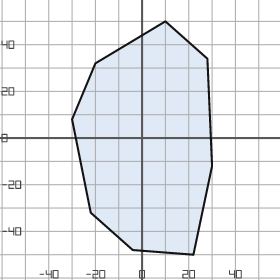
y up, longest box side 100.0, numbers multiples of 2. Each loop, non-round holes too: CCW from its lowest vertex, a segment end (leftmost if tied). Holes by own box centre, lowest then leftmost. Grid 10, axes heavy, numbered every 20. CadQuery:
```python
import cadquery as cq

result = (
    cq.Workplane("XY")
    .moveTo(22.0, -50.0)
    .lineTo(30.0, -12.0)
    .lineTo(28.0, 34.0)
    .lineTo(10.0, 50.0)
    .lineTo(-20.0, 32.0)
    .lineTo(-30.0, 8.0)
    .lineTo(-22.0, -32.0)
    .lineTo(-4.0, -48.0)
    .close()
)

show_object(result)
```